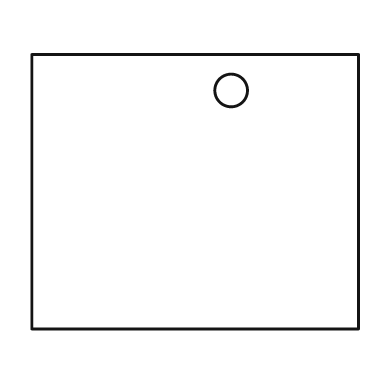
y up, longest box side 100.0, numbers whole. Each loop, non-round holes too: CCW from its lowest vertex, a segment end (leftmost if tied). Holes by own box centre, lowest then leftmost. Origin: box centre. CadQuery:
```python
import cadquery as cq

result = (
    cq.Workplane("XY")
    .moveTo(-50.0, -42.0)
    .lineTo(50.0, -42.0)
    .lineTo(50.0, 42.0)
    .lineTo(-50.0, 42.0)
    .close()
    .moveTo(11.0, 31.0)
    .circle(5.0)
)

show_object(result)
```